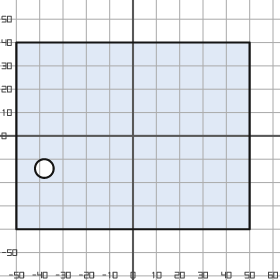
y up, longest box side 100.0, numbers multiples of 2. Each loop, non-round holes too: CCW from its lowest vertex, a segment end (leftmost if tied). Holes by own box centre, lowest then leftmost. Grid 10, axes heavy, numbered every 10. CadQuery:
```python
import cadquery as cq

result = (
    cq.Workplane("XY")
    .moveTo(-50.0, -40.0)
    .lineTo(50.0, -40.0)
    .lineTo(50.0, 40.0)
    .lineTo(-50.0, 40.0)
    .close()
    .moveTo(-38.0, -14.0)
    .circle(4.0)
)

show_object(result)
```